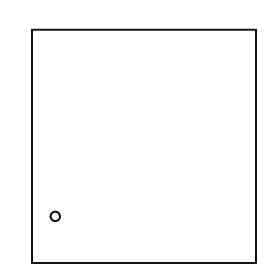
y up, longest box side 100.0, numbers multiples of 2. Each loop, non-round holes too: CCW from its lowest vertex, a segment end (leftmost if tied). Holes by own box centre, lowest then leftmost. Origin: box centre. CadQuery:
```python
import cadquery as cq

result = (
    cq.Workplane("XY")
    .moveTo(-48.0, -50.0)
    .lineTo(48.0, -50.0)
    .lineTo(48.0, 50.0)
    .lineTo(-48.0, 50.0)
    .close()
    .moveTo(-38.0, -30.0)
    .circle(2.0)
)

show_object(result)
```